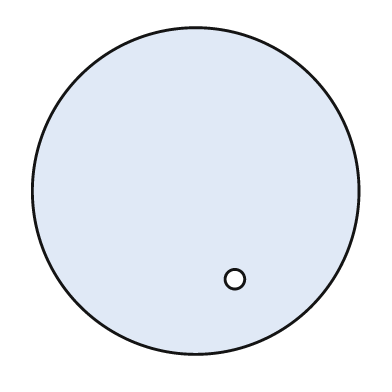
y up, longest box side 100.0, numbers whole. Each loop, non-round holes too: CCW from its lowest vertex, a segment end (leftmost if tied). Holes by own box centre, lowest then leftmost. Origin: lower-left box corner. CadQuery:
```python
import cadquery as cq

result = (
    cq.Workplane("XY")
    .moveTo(50.0, 50.0)
    .circle(50.0)
    .moveTo(62.0, 23.0)
    .circle(3.0)
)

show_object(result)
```